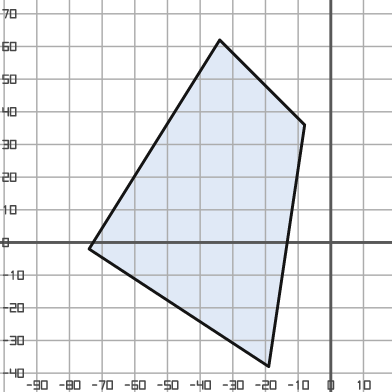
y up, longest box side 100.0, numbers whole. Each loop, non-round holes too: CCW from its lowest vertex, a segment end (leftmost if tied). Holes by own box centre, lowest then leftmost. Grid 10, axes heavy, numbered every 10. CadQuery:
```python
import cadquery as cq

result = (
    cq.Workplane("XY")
    .moveTo(-19.0, -38.0)
    .lineTo(-8.0, 36.0)
    .lineTo(-34.0, 62.0)
    .lineTo(-74.0, -2.0)
    .close()
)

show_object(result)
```